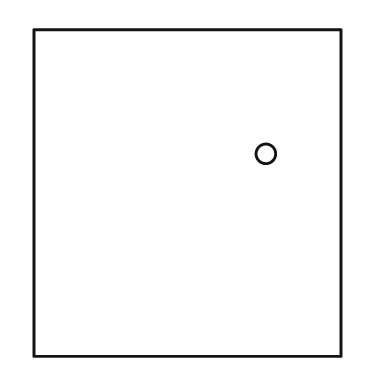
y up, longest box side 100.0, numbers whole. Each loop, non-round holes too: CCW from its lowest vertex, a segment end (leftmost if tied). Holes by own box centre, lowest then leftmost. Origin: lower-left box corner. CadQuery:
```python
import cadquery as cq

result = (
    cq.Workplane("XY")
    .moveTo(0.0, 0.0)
    .lineTo(94.0, 0.0)
    .lineTo(94.0, 100.0)
    .lineTo(0.0, 100.0)
    .close()
    .moveTo(71.0, 62.0)
    .circle(3.0)
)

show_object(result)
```